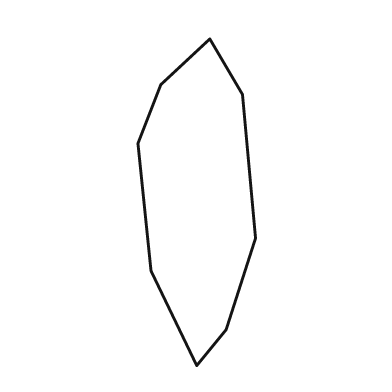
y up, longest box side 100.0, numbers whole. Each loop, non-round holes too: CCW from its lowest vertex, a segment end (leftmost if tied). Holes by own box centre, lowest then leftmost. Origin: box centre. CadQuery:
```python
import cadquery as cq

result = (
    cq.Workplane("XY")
    .moveTo(0.0, -50.0)
    .lineTo(9.0, -39.0)
    .lineTo(18.0, -11.0)
    .lineTo(14.0, 33.0)
    .lineTo(4.0, 50.0)
    .lineTo(-11.0, 36.0)
    .lineTo(-18.0, 18.0)
    .lineTo(-14.0, -21.0)
    .close()
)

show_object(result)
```